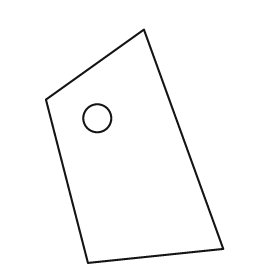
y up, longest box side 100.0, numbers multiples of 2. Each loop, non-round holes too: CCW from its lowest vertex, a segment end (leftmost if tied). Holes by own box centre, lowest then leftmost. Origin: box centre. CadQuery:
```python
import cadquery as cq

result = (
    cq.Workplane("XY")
    .moveTo(-20.0, -50.0)
    .lineTo(38.0, -44.0)
    .lineTo(4.0, 50.0)
    .lineTo(-38.0, 20.0)
    .close()
    .moveTo(-16.0, 12.0)
    .circle(6.0)
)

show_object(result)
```